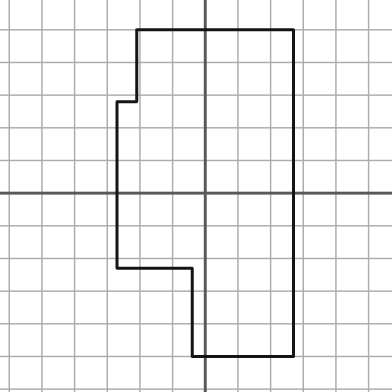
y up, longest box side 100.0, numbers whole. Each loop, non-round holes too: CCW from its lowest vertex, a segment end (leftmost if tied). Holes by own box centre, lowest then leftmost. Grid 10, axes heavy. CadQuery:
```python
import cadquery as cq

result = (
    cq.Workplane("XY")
    .moveTo(-4.0, -50.0)
    .lineTo(27.0, -50.0)
    .lineTo(27.0, 50.0)
    .lineTo(-21.0, 50.0)
    .lineTo(-21.0, 28.0)
    .lineTo(-27.0, 28.0)
    .lineTo(-27.0, -23.0)
    .lineTo(-4.0, -23.0)
    .close()
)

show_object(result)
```